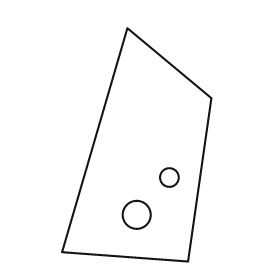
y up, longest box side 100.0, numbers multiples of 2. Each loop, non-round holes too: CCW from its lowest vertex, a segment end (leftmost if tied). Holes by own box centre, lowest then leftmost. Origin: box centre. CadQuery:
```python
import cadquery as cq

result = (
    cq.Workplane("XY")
    .moveTo(22.0, -50.0)
    .lineTo(32.0, 20.0)
    .lineTo(-4.0, 50.0)
    .lineTo(-32.0, -46.0)
    .close()
    .moveTo(0.0, -30.0)
    .circle(6.0)
    .moveTo(14.0, -14.0)
    .circle(4.0)
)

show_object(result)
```